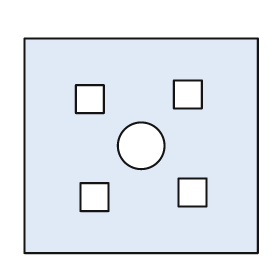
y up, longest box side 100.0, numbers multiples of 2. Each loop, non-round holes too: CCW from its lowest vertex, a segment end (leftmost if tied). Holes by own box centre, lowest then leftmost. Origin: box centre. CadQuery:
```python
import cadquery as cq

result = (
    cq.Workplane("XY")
    .moveTo(-50.0, -46.0)
    .lineTo(50.0, -46.0)
    .lineTo(50.0, 46.0)
    .lineTo(-50.0, 46.0)
    .close()
    .moveTo(-26.0, -28.0)
    .lineTo(-14.0, -28.0)
    .lineTo(-14.0, -16.0)
    .lineTo(-26.0, -16.0)
    .close()
    .moveTo(16.0, -26.0)
    .lineTo(28.0, -26.0)
    .lineTo(28.0, -14.0)
    .lineTo(16.0, -14.0)
    .close()
    .moveTo(0.0, 0.0)
    .circle(10.0)
    .moveTo(-28.0, 14.0)
    .lineTo(-16.0, 14.0)
    .lineTo(-16.0, 26.0)
    .lineTo(-28.0, 26.0)
    .close()
    .moveTo(14.0, 16.0)
    .lineTo(26.0, 16.0)
    .lineTo(26.0, 28.0)
    .lineTo(14.0, 28.0)
    .close()
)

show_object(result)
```